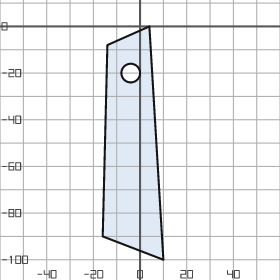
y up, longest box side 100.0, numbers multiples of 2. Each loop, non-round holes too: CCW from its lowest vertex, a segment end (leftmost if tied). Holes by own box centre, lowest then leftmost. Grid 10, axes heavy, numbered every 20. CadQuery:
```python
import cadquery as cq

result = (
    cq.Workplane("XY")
    .moveTo(10.0, -100.0)
    .lineTo(4.0, 0.0)
    .lineTo(-14.0, -8.0)
    .lineTo(-16.0, -90.0)
    .close()
    .moveTo(-4.0, -20.0)
    .circle(4.0)
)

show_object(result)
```